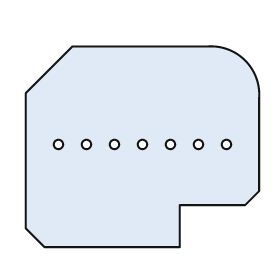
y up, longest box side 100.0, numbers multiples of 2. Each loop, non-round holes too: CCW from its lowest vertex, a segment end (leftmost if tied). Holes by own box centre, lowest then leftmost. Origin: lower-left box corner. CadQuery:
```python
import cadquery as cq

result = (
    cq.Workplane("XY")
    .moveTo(8.0, 0.0)
    .lineTo(66.0, 0.0)
    .lineTo(66.0, 18.0)
    .lineTo(94.0, 18.0)
    .lineTo(100.0, 24.0)
    .lineTo(100.0, 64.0)
    .threePointArc((94.0, 80.0), (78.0, 86.0))
    .lineTo(20.0, 86.0)
    .lineTo(0.0, 66.0)
    .lineTo(0.0, 8.0)
    .close()
    .moveTo(14.0, 44.0)
    .circle(2.0)
    .moveTo(26.0, 44.0)
    .circle(2.0)
    .moveTo(38.0, 44.0)
    .circle(2.0)
    .moveTo(50.0, 44.0)
    .circle(2.0)
    .moveTo(62.0, 44.0)
    .circle(2.0)
    .moveTo(74.0, 44.0)
    .circle(2.0)
    .moveTo(86.0, 44.0)
    .circle(2.0)
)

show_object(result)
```